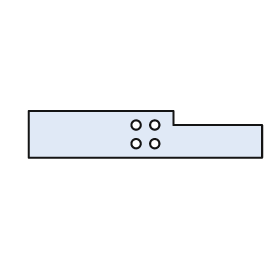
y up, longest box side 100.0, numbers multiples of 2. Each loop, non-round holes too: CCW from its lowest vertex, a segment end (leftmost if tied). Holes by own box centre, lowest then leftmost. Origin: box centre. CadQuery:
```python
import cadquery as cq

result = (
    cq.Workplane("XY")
    .moveTo(-50.0, -10.0)
    .lineTo(50.0, -10.0)
    .lineTo(50.0, 4.0)
    .lineTo(12.0, 4.0)
    .lineTo(12.0, 10.0)
    .lineTo(-50.0, 10.0)
    .close()
    .moveTo(-4.0, -4.0)
    .circle(2.0)
    .moveTo(4.0, -4.0)
    .circle(2.0)
    .moveTo(-4.0, 4.0)
    .circle(2.0)
    .moveTo(4.0, 4.0)
    .circle(2.0)
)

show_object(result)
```